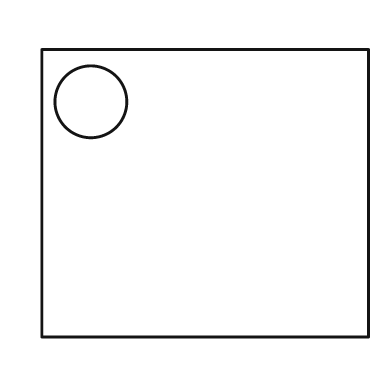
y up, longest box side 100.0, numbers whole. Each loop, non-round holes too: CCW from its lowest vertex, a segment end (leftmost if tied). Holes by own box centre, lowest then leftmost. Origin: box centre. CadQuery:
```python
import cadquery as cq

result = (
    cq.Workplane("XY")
    .moveTo(-50.0, -44.0)
    .lineTo(50.0, -44.0)
    .lineTo(50.0, 44.0)
    .lineTo(-50.0, 44.0)
    .close()
    .moveTo(-35.0, 28.0)
    .circle(11.0)
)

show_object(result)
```